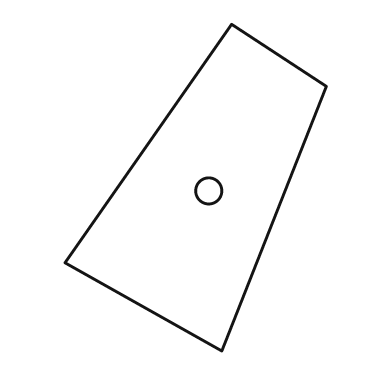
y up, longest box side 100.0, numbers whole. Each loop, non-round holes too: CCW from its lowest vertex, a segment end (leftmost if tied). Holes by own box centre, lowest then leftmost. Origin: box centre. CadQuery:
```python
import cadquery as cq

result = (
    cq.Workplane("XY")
    .moveTo(8.0, -50.0)
    .lineTo(40.0, 31.0)
    .lineTo(11.0, 50.0)
    .lineTo(-40.0, -23.0)
    .close()
    .moveTo(4.0, -1.0)
    .circle(4.0)
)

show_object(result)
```